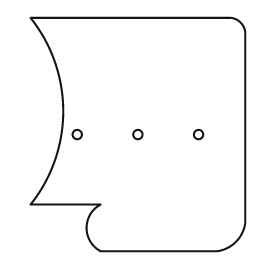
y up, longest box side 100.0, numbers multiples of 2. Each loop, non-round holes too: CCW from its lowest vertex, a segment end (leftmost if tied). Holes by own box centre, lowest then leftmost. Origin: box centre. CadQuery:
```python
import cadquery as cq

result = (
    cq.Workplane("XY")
    .moveTo(-16.0, -50.0)
    .lineTo(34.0, -50.0)
    .threePointArc((42.0, -46.0), (46.0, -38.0))
    .lineTo(46.0, 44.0)
    .threePointArc((44.0, 48.0), (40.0, 50.0))
    .lineTo(-46.0, 50.0)
    .threePointArc((-32.0, 10.0), (-46.0, -30.0))
    .lineTo(-16.0, -30.0)
    .threePointArc((-22.0, -40.0), (-16.0, -50.0))
    .close()
    .moveTo(-26.0, 0.0)
    .circle(2.0)
    .moveTo(0.0, 0.0)
    .circle(2.0)
    .moveTo(26.0, 0.0)
    .circle(2.0)
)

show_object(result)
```